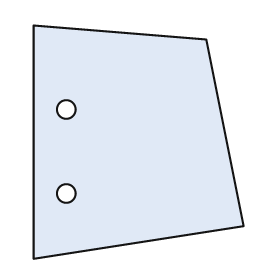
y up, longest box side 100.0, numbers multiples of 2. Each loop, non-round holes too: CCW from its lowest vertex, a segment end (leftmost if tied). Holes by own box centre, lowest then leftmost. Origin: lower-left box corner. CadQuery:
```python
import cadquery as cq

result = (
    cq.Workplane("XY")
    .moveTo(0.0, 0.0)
    .lineTo(90.0, 14.0)
    .lineTo(74.0, 94.0)
    .lineTo(0.0, 100.0)
    .close()
    .moveTo(14.0, 28.0)
    .circle(4.0)
    .moveTo(14.0, 64.0)
    .circle(4.0)
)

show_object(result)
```